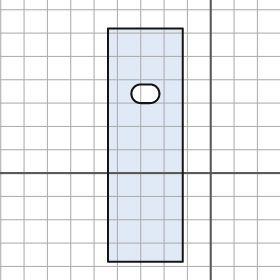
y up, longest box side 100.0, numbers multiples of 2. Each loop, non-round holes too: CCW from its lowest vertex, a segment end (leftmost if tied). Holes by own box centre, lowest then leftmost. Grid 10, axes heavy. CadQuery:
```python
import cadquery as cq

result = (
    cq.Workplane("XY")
    .moveTo(-44.0, -38.0)
    .lineTo(-12.0, -38.0)
    .lineTo(-12.0, 62.0)
    .lineTo(-44.0, 62.0)
    .close()
    .moveTo(-30.0, 30.0)
    .lineTo(-26.0, 30.0)
    .threePointArc((-22.0, 34.0), (-26.0, 38.0))
    .lineTo(-30.0, 38.0)
    .threePointArc((-34.0, 34.0), (-30.0, 30.0))
    .close()
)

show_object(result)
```